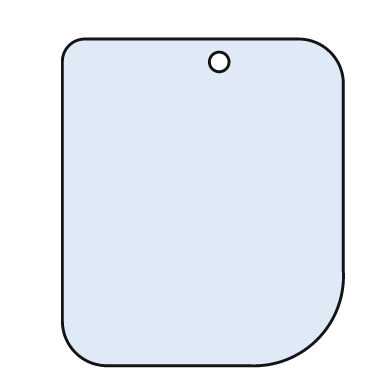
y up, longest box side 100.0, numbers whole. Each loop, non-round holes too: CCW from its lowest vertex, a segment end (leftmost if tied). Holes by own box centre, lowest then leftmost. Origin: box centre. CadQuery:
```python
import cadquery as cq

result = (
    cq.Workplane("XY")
    .moveTo(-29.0, -50.0)
    .lineTo(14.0, -50.0)
    .threePointArc((35.0, -42.0), (43.0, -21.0))
    .lineTo(43.0, 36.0)
    .threePointArc((39.0, 46.0), (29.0, 50.0))
    .lineTo(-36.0, 50.0)
    .threePointArc((-41.0, 48.0), (-43.0, 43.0))
    .lineTo(-43.0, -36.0)
    .threePointArc((-39.0, -46.0), (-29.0, -50.0))
    .close()
    .moveTo(5.0, 43.0)
    .circle(3.0)
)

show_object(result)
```